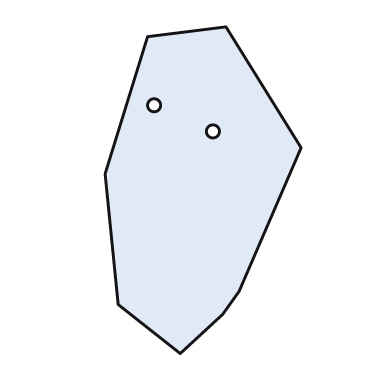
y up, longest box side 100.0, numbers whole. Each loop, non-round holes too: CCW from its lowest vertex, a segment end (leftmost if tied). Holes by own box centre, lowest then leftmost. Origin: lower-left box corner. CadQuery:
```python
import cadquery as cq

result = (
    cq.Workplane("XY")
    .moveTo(23.0, 0.0)
    .lineTo(36.0, 12.0)
    .lineTo(41.0, 19.0)
    .lineTo(60.0, 63.0)
    .lineTo(37.0, 100.0)
    .lineTo(13.0, 97.0)
    .lineTo(0.0, 55.0)
    .lineTo(4.0, 15.0)
    .close()
    .moveTo(33.0, 68.0)
    .circle(2.0)
    .moveTo(15.0, 76.0)
    .circle(2.0)
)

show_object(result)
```